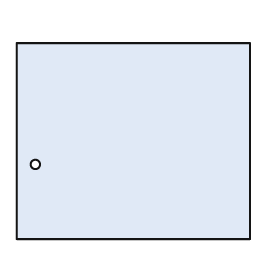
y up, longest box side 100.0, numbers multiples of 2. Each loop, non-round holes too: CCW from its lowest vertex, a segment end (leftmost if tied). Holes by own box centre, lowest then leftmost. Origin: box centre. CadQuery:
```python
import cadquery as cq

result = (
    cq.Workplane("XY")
    .moveTo(-50.0, -42.0)
    .lineTo(50.0, -42.0)
    .lineTo(50.0, 42.0)
    .lineTo(-50.0, 42.0)
    .close()
    .moveTo(-42.0, -10.0)
    .circle(2.0)
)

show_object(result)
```